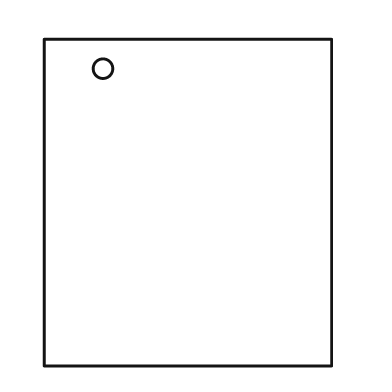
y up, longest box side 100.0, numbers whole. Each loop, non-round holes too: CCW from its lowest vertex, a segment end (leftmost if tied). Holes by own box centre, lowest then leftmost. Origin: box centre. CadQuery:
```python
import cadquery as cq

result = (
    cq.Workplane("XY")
    .moveTo(-44.0, -50.0)
    .lineTo(44.0, -50.0)
    .lineTo(44.0, 50.0)
    .lineTo(-44.0, 50.0)
    .close()
    .moveTo(-26.0, 41.0)
    .circle(3.0)
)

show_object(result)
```